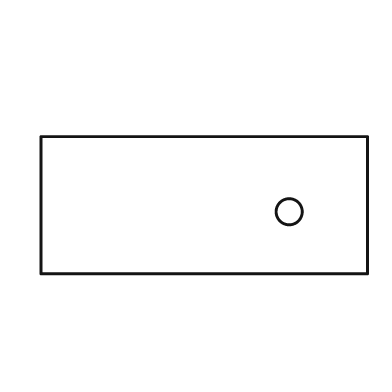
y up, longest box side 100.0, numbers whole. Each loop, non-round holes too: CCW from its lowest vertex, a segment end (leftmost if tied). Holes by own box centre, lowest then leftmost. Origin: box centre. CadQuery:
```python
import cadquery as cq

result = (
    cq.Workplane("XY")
    .moveTo(-50.0, -21.0)
    .lineTo(50.0, -21.0)
    .lineTo(50.0, 21.0)
    .lineTo(-50.0, 21.0)
    .close()
    .moveTo(26.0, -2.0)
    .circle(4.0)
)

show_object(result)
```